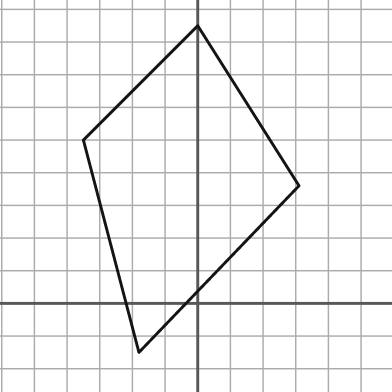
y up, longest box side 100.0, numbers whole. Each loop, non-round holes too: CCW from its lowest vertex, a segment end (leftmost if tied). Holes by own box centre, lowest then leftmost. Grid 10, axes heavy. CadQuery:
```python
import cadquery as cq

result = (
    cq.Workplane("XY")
    .moveTo(-18.0, -15.0)
    .lineTo(31.0, 36.0)
    .lineTo(0.0, 85.0)
    .lineTo(-35.0, 50.0)
    .close()
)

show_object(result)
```